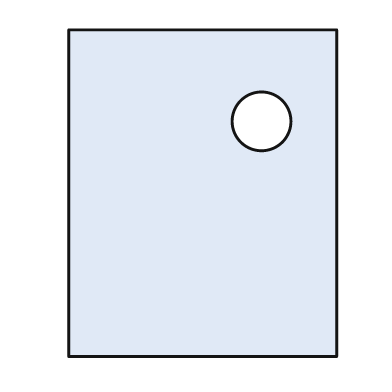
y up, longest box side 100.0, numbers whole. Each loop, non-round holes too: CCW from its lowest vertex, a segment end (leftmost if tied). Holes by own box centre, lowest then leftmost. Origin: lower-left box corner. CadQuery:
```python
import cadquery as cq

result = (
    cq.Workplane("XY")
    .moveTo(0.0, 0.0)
    .lineTo(82.0, 0.0)
    .lineTo(82.0, 100.0)
    .lineTo(0.0, 100.0)
    .close()
    .moveTo(59.0, 72.0)
    .circle(9.0)
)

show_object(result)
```